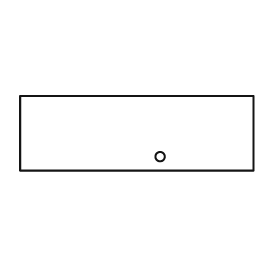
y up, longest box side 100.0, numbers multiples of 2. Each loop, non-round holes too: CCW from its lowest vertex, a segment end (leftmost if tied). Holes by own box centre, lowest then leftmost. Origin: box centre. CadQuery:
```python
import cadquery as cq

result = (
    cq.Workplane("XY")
    .moveTo(-50.0, -16.0)
    .lineTo(50.0, -16.0)
    .lineTo(50.0, 16.0)
    .lineTo(-50.0, 16.0)
    .close()
    .moveTo(10.0, -10.0)
    .circle(2.0)
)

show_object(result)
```